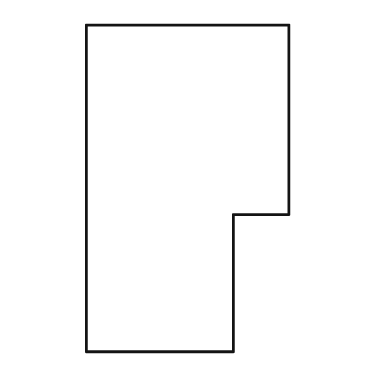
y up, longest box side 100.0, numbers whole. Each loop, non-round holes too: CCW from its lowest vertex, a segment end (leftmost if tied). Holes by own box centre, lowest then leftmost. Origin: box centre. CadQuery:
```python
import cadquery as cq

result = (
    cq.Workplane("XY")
    .moveTo(-31.0, -50.0)
    .lineTo(14.0, -50.0)
    .lineTo(14.0, -8.0)
    .lineTo(31.0, -8.0)
    .lineTo(31.0, 50.0)
    .lineTo(-31.0, 50.0)
    .close()
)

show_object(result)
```